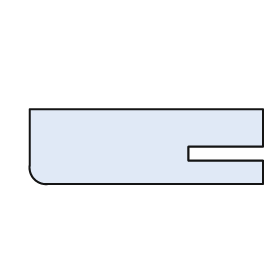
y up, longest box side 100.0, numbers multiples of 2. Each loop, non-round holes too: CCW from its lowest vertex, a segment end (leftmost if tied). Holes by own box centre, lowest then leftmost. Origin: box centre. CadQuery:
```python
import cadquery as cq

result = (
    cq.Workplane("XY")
    .moveTo(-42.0, -16.0)
    .lineTo(50.0, -16.0)
    .lineTo(50.0, -6.0)
    .lineTo(18.0, -6.0)
    .lineTo(18.0, 0.0)
    .lineTo(50.0, 0.0)
    .lineTo(50.0, 16.0)
    .lineTo(-50.0, 16.0)
    .lineTo(-50.0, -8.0)
    .threePointArc((-48.0, -14.0), (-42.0, -16.0))
    .close()
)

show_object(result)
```